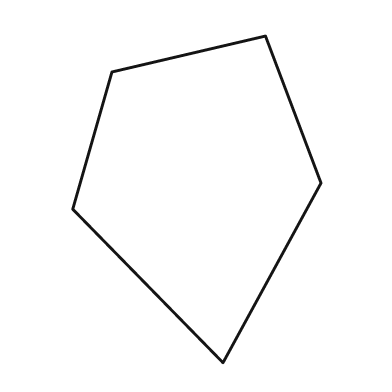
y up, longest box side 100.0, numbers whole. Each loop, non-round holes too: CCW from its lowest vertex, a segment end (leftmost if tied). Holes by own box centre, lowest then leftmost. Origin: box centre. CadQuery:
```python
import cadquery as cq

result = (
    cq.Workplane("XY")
    .moveTo(8.0, -50.0)
    .lineTo(38.0, 5.0)
    .lineTo(21.0, 50.0)
    .lineTo(-26.0, 39.0)
    .lineTo(-38.0, -3.0)
    .close()
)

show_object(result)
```